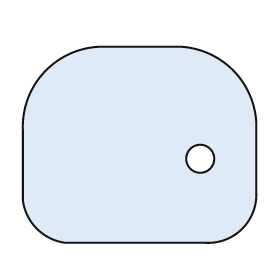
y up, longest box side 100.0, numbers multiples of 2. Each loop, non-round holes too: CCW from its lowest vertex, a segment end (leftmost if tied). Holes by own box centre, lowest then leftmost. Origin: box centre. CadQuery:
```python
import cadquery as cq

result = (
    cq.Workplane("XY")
    .moveTo(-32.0, -42.0)
    .lineTo(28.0, -42.0)
    .threePointArc((44.0, -36.0), (50.0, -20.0))
    .lineTo(50.0, 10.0)
    .threePointArc((40.0, 32.0), (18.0, 42.0))
    .lineTo(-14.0, 42.0)
    .threePointArc((-40.0, 32.0), (-50.0, 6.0))
    .lineTo(-50.0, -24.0)
    .threePointArc((-44.0, -36.0), (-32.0, -42.0))
    .close()
    .moveTo(26.0, -6.0)
    .circle(6.0)
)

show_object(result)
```